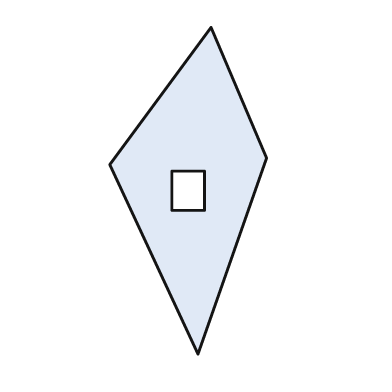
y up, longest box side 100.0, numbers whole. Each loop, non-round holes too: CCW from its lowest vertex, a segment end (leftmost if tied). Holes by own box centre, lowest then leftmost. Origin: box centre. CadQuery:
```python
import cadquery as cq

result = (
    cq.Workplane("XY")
    .moveTo(3.0, -50.0)
    .lineTo(24.0, 10.0)
    .lineTo(7.0, 50.0)
    .lineTo(-24.0, 8.0)
    .close()
    .moveTo(-5.0, -6.0)
    .lineTo(5.0, -6.0)
    .lineTo(5.0, 6.0)
    .lineTo(-5.0, 6.0)
    .close()
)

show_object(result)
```